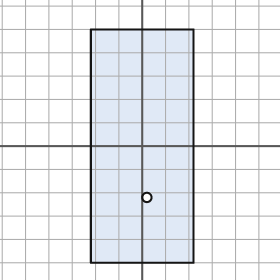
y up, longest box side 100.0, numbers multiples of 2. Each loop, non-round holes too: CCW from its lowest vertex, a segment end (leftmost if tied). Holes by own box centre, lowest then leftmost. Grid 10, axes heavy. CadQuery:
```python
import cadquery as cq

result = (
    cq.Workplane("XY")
    .moveTo(-22.0, -50.0)
    .lineTo(22.0, -50.0)
    .lineTo(22.0, 50.0)
    .lineTo(-22.0, 50.0)
    .close()
    .moveTo(2.0, -22.0)
    .circle(2.0)
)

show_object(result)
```